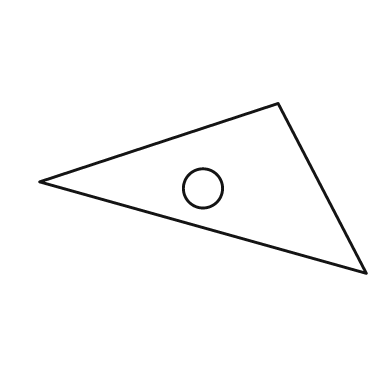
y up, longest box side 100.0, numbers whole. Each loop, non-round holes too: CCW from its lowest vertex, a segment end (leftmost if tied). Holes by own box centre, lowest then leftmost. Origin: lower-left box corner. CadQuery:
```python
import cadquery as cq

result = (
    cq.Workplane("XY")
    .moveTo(100.0, 0.0)
    .lineTo(73.0, 52.0)
    .lineTo(0.0, 28.0)
    .close()
    .moveTo(50.0, 26.0)
    .circle(6.0)
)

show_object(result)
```